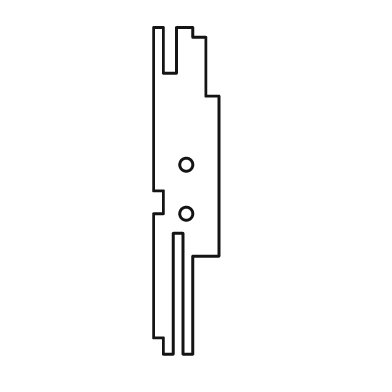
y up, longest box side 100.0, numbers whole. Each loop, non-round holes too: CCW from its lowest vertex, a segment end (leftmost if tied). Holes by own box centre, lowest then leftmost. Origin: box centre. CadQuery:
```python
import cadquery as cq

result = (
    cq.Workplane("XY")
    .moveTo(-7.0, -50.0)
    .lineTo(-4.0, -50.0)
    .lineTo(-4.0, -13.0)
    .lineTo(-1.0, -13.0)
    .lineTo(-1.0, -50.0)
    .lineTo(2.0, -50.0)
    .lineTo(2.0, -20.0)
    .lineTo(10.0, -20.0)
    .lineTo(10.0, 29.0)
    .lineTo(6.0, 29.0)
    .lineTo(6.0, 47.0)
    .lineTo(2.0, 47.0)
    .lineTo(2.0, 50.0)
    .lineTo(-3.0, 50.0)
    .lineTo(-3.0, 36.0)
    .lineTo(-7.0, 36.0)
    .lineTo(-7.0, 50.0)
    .lineTo(-10.0, 50.0)
    .lineTo(-10.0, 0.0)
    .lineTo(-7.0, 0.0)
    .lineTo(-7.0, -7.0)
    .lineTo(-10.0, -7.0)
    .lineTo(-10.0, -45.0)
    .lineTo(-7.0, -45.0)
    .close()
    .moveTo(0.0, -7.0)
    .circle(2.0)
    .moveTo(0.0, 8.0)
    .circle(2.0)
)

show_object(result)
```